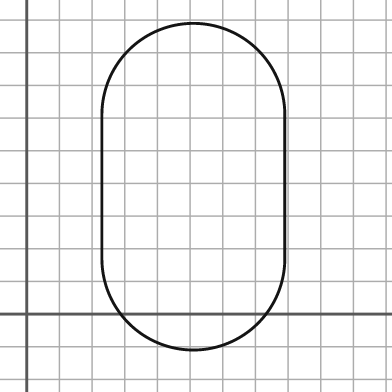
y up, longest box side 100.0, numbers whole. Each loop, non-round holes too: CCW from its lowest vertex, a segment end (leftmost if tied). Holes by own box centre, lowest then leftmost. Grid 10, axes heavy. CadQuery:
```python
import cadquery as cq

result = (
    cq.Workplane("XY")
    .moveTo(23.0, 17.0)
    .threePointArc((51.0, -11.0), (79.0, 17.0))
    .lineTo(79.0, 61.0)
    .threePointArc((51.0, 89.0), (23.0, 61.0))
    .close()
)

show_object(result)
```